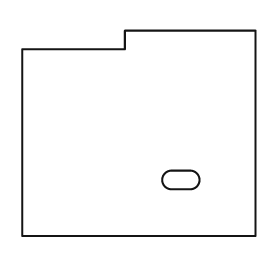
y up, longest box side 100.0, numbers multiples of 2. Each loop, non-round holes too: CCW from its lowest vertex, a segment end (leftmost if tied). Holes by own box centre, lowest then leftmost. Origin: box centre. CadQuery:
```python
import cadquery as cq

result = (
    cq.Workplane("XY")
    .moveTo(-50.0, -44.0)
    .lineTo(50.0, -44.0)
    .lineTo(50.0, 44.0)
    .lineTo(-6.0, 44.0)
    .lineTo(-6.0, 36.0)
    .lineTo(-50.0, 36.0)
    .close()
    .moveTo(14.0, -24.0)
    .lineTo(22.0, -24.0)
    .threePointArc((26.0, -20.0), (22.0, -16.0))
    .lineTo(14.0, -16.0)
    .threePointArc((10.0, -20.0), (14.0, -24.0))
    .close()
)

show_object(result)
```